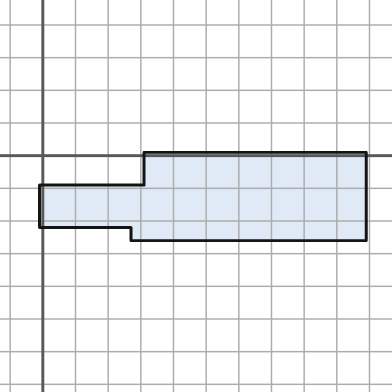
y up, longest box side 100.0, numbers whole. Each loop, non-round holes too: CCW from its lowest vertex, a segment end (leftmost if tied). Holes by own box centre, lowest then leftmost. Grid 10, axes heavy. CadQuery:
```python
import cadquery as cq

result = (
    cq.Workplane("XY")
    .moveTo(27.0, -26.0)
    .lineTo(99.0, -26.0)
    .lineTo(99.0, 1.0)
    .lineTo(31.0, 1.0)
    .lineTo(31.0, -9.0)
    .lineTo(-1.0, -9.0)
    .lineTo(-1.0, -22.0)
    .lineTo(27.0, -22.0)
    .close()
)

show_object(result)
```